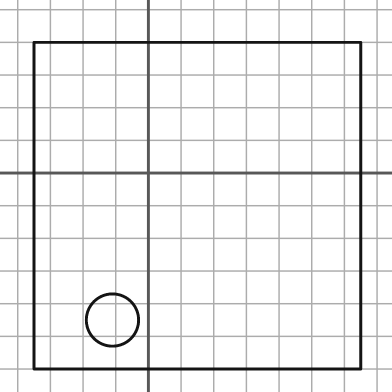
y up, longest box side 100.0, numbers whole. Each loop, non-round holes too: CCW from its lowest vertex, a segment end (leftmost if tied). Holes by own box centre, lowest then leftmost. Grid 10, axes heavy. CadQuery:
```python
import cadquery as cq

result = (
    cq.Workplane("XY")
    .moveTo(-35.0, -60.0)
    .lineTo(65.0, -60.0)
    .lineTo(65.0, 40.0)
    .lineTo(-35.0, 40.0)
    .close()
    .moveTo(-11.0, -45.0)
    .circle(8.0)
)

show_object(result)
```